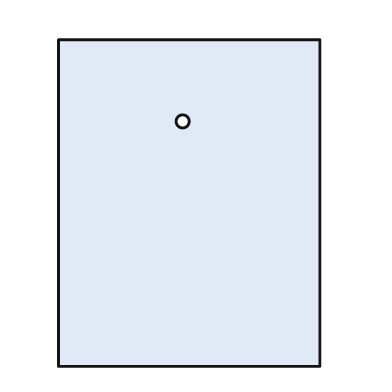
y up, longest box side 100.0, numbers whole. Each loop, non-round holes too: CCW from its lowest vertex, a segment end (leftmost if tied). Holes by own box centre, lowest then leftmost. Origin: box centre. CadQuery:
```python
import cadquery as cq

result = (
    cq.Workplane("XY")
    .moveTo(-40.0, -50.0)
    .lineTo(40.0, -50.0)
    .lineTo(40.0, 50.0)
    .lineTo(-40.0, 50.0)
    .close()
    .moveTo(-2.0, 25.0)
    .circle(2.0)
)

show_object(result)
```